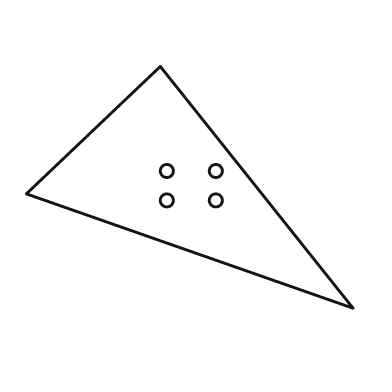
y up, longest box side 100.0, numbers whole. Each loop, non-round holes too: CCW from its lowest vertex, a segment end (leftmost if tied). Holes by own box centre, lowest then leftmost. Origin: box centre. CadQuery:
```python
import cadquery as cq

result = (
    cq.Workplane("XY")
    .moveTo(50.0, -37.0)
    .lineTo(-9.0, 37.0)
    .lineTo(-50.0, -2.0)
    .close()
    .moveTo(-7.0, -4.0)
    .circle(2.0)
    .moveTo(8.0, -4.0)
    .circle(2.0)
    .moveTo(-7.0, 5.0)
    .circle(2.0)
    .moveTo(8.0, 5.0)
    .circle(2.0)
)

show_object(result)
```